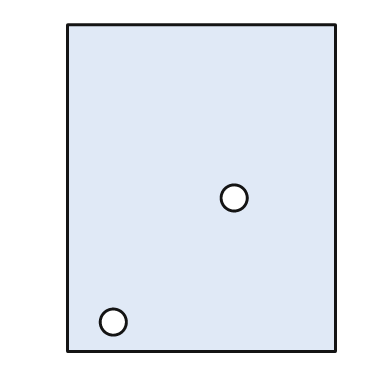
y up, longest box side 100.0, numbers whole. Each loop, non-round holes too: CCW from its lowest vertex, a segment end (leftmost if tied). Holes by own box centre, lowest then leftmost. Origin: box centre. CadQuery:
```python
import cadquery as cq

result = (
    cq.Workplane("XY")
    .moveTo(-41.0, -50.0)
    .lineTo(41.0, -50.0)
    .lineTo(41.0, 50.0)
    .lineTo(-41.0, 50.0)
    .close()
    .moveTo(-27.0, -41.0)
    .circle(4.0)
    .moveTo(10.0, -3.0)
    .circle(4.0)
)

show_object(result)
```